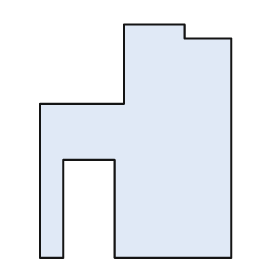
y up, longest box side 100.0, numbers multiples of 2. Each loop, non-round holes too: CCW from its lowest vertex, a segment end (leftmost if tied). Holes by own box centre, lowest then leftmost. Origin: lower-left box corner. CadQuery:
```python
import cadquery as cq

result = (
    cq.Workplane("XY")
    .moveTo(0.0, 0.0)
    .lineTo(10.0, 0.0)
    .lineTo(10.0, 42.0)
    .lineTo(32.0, 42.0)
    .lineTo(32.0, 0.0)
    .lineTo(82.0, 0.0)
    .lineTo(82.0, 94.0)
    .lineTo(62.0, 94.0)
    .lineTo(62.0, 100.0)
    .lineTo(36.0, 100.0)
    .lineTo(36.0, 66.0)
    .lineTo(0.0, 66.0)
    .close()
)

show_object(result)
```